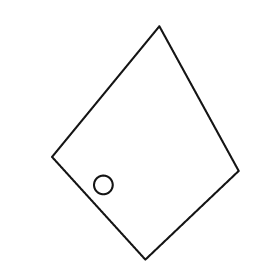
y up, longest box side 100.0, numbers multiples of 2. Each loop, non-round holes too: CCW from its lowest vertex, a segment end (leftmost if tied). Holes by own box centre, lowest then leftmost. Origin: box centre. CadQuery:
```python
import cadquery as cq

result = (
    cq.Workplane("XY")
    .moveTo(0.0, -50.0)
    .lineTo(40.0, -12.0)
    .lineTo(6.0, 50.0)
    .lineTo(-40.0, -6.0)
    .close()
    .moveTo(-18.0, -18.0)
    .circle(4.0)
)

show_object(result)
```